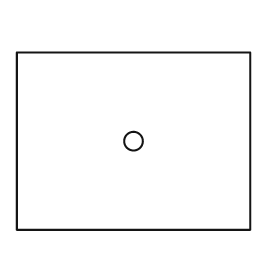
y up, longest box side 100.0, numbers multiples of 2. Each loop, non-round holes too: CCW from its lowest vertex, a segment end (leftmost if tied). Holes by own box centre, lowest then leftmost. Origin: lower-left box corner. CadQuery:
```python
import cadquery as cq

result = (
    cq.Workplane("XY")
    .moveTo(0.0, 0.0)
    .lineTo(100.0, 0.0)
    .lineTo(100.0, 76.0)
    .lineTo(0.0, 76.0)
    .close()
    .moveTo(50.0, 38.0)
    .circle(4.0)
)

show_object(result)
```